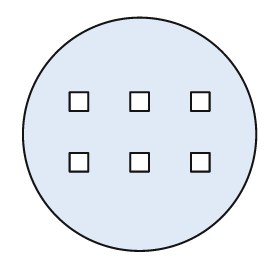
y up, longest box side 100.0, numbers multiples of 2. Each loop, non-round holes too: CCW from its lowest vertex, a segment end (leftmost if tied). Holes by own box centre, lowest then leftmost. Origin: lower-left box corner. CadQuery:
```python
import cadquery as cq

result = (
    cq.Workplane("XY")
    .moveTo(50.0, 50.0)
    .circle(50.0)
    .moveTo(20.0, 34.0)
    .lineTo(28.0, 34.0)
    .lineTo(28.0, 42.0)
    .lineTo(20.0, 42.0)
    .close()
    .moveTo(46.0, 34.0)
    .lineTo(54.0, 34.0)
    .lineTo(54.0, 42.0)
    .lineTo(46.0, 42.0)
    .close()
    .moveTo(72.0, 34.0)
    .lineTo(80.0, 34.0)
    .lineTo(80.0, 42.0)
    .lineTo(72.0, 42.0)
    .close()
    .moveTo(20.0, 60.0)
    .lineTo(28.0, 60.0)
    .lineTo(28.0, 68.0)
    .lineTo(20.0, 68.0)
    .close()
    .moveTo(46.0, 60.0)
    .lineTo(54.0, 60.0)
    .lineTo(54.0, 68.0)
    .lineTo(46.0, 68.0)
    .close()
    .moveTo(72.0, 60.0)
    .lineTo(80.0, 60.0)
    .lineTo(80.0, 68.0)
    .lineTo(72.0, 68.0)
    .close()
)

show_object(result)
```